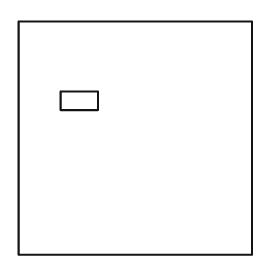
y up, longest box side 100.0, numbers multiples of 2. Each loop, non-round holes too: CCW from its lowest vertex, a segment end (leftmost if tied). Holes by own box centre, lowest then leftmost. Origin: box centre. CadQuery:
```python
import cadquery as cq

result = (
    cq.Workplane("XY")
    .moveTo(-50.0, -50.0)
    .lineTo(50.0, -50.0)
    .lineTo(50.0, 50.0)
    .lineTo(-50.0, 50.0)
    .close()
    .moveTo(-32.0, 12.0)
    .lineTo(-16.0, 12.0)
    .lineTo(-16.0, 20.0)
    .lineTo(-32.0, 20.0)
    .close()
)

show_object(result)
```